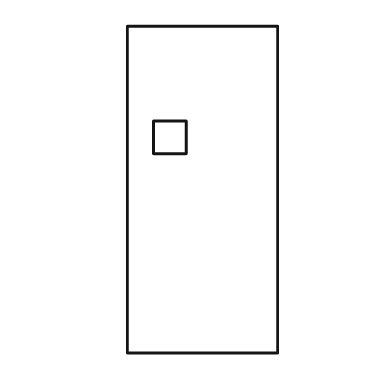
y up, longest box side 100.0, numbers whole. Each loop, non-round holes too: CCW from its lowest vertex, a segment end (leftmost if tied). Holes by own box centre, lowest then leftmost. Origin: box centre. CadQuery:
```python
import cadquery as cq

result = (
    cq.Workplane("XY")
    .moveTo(-23.0, -50.0)
    .lineTo(23.0, -50.0)
    .lineTo(23.0, 50.0)
    .lineTo(-23.0, 50.0)
    .close()
    .moveTo(-15.0, 11.0)
    .lineTo(-5.0, 11.0)
    .lineTo(-5.0, 21.0)
    .lineTo(-15.0, 21.0)
    .close()
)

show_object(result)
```